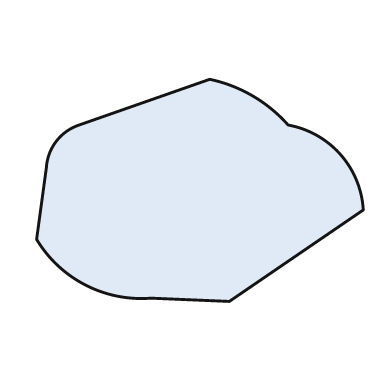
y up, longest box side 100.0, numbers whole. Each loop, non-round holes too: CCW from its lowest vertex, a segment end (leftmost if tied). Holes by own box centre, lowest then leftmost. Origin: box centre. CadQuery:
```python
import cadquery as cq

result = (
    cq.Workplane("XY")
    .moveTo(9.0, -34.0)
    .lineTo(50.0, -6.0)
    .threePointArc((43.0, 11.0), (27.0, 20.0))
    .threePointArc((16.0, 29.0), (3.0, 34.0))
    .lineTo(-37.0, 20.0)
    .threePointArc((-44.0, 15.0), (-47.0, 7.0))
    .lineTo(-50.0, -15.0)
    .threePointArc((-35.0, -29.0), (-15.0, -33.0))
    .close()
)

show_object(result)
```